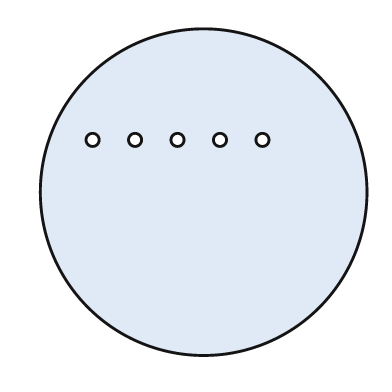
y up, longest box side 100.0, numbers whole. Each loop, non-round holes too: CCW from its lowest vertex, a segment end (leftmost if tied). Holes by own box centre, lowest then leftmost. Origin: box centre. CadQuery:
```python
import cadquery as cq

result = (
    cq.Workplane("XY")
    .moveTo(0.0, 0.0)
    .circle(50.0)
    .moveTo(-34.0, 16.0)
    .circle(2.0)
    .moveTo(-21.0, 16.0)
    .circle(2.0)
    .moveTo(-8.0, 16.0)
    .circle(2.0)
    .moveTo(5.0, 16.0)
    .circle(2.0)
    .moveTo(18.0, 16.0)
    .circle(2.0)
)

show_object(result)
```